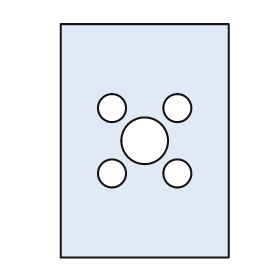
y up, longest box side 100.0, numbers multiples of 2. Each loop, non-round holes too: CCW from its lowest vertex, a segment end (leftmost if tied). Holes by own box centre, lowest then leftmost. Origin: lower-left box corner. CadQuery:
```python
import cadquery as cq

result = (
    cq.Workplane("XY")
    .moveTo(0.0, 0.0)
    .lineTo(72.0, 0.0)
    .lineTo(72.0, 100.0)
    .lineTo(0.0, 100.0)
    .close()
    .moveTo(22.0, 36.0)
    .circle(6.0)
    .moveTo(50.0, 36.0)
    .circle(6.0)
    .moveTo(36.0, 50.0)
    .circle(10.0)
    .moveTo(22.0, 64.0)
    .circle(6.0)
    .moveTo(50.0, 64.0)
    .circle(6.0)
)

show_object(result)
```